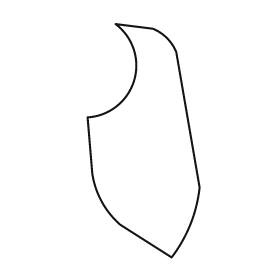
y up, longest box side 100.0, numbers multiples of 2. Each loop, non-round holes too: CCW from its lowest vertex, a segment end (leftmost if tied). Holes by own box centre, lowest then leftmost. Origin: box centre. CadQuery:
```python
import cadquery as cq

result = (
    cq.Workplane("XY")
    .moveTo(12.0, -50.0)
    .threePointArc((20.0, -36.0), (24.0, -20.0))
    .lineTo(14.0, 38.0)
    .threePointArc((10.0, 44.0), (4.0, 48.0))
    .lineTo(-12.0, 50.0)
    .threePointArc((-4.0, 26.0), (-24.0, 10.0))
    .lineTo(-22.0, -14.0)
    .threePointArc((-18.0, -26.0), (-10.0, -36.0))
    .close()
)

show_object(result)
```